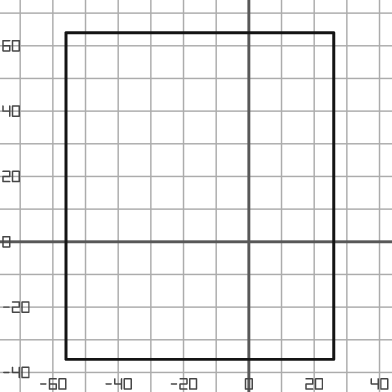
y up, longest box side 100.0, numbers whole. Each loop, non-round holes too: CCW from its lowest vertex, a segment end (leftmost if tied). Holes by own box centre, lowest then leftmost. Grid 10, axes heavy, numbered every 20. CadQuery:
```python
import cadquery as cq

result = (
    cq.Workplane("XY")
    .moveTo(-56.0, -36.0)
    .lineTo(26.0, -36.0)
    .lineTo(26.0, 64.0)
    .lineTo(-56.0, 64.0)
    .close()
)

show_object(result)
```